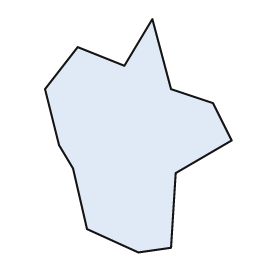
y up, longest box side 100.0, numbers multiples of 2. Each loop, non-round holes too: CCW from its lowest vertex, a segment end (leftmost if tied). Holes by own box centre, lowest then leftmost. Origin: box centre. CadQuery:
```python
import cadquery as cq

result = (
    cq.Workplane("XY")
    .moveTo(0.0, -50.0)
    .lineTo(14.0, -48.0)
    .lineTo(16.0, -16.0)
    .lineTo(40.0, -2.0)
    .lineTo(32.0, 14.0)
    .lineTo(14.0, 20.0)
    .lineTo(6.0, 50.0)
    .lineTo(-6.0, 30.0)
    .lineTo(-26.0, 38.0)
    .lineTo(-40.0, 20.0)
    .lineTo(-34.0, -4.0)
    .lineTo(-28.0, -14.0)
    .lineTo(-22.0, -40.0)
    .close()
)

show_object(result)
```